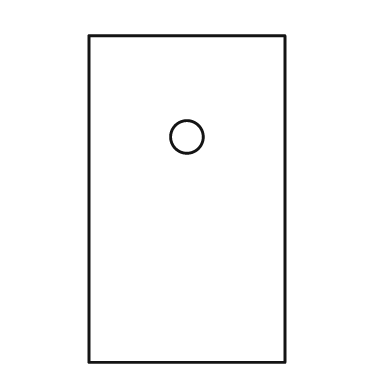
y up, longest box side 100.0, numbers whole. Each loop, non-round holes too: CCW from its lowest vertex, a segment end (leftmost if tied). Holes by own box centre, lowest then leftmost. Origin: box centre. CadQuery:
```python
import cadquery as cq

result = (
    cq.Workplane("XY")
    .moveTo(-30.0, -50.0)
    .lineTo(30.0, -50.0)
    .lineTo(30.0, 50.0)
    .lineTo(-30.0, 50.0)
    .close()
    .moveTo(0.0, 19.0)
    .circle(5.0)
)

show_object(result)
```